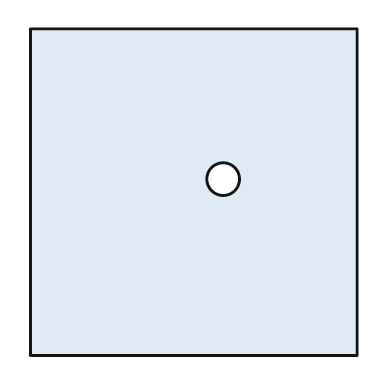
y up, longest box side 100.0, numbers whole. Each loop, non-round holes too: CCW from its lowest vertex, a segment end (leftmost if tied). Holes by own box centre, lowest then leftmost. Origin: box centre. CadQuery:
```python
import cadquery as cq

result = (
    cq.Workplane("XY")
    .moveTo(-50.0, -50.0)
    .lineTo(50.0, -50.0)
    .lineTo(50.0, 50.0)
    .lineTo(-50.0, 50.0)
    .close()
    .moveTo(9.0, 4.0)
    .circle(5.0)
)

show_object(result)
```